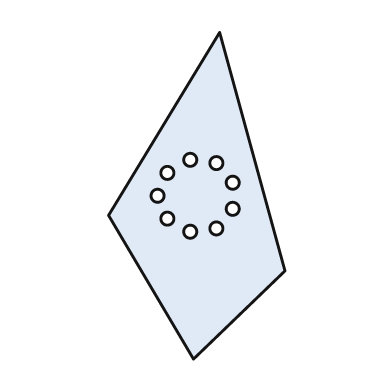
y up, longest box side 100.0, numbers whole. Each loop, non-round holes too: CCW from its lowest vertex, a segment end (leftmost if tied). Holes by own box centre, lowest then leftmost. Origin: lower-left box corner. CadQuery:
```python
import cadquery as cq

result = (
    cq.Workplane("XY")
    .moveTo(26.0, 0.0)
    .lineTo(54.0, 27.0)
    .lineTo(34.0, 100.0)
    .lineTo(0.0, 44.0)
    .close()
    .moveTo(25.0, 39.0)
    .circle(2.0)
    .moveTo(33.0, 40.0)
    .circle(2.0)
    .moveTo(18.0, 43.0)
    .circle(2.0)
    .moveTo(38.0, 46.0)
    .circle(2.0)
    .moveTo(15.0, 50.0)
    .circle(2.0)
    .moveTo(38.0, 54.0)
    .circle(2.0)
    .moveTo(18.0, 57.0)
    .circle(2.0)
    .moveTo(33.0, 60.0)
    .circle(2.0)
    .moveTo(25.0, 61.0)
    .circle(2.0)
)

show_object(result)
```